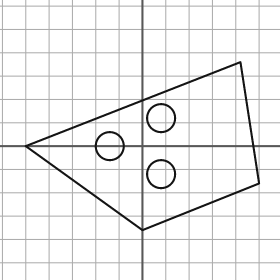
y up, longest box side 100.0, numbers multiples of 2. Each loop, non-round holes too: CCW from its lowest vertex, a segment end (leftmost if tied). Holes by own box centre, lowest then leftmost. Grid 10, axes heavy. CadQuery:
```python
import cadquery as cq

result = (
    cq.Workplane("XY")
    .moveTo(0.0, -36.0)
    .lineTo(50.0, -16.0)
    .lineTo(42.0, 36.0)
    .lineTo(-50.0, 0.0)
    .close()
    .moveTo(8.0, -12.0)
    .circle(6.0)
    .moveTo(-14.0, 0.0)
    .circle(6.0)
    .moveTo(8.0, 12.0)
    .circle(6.0)
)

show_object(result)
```